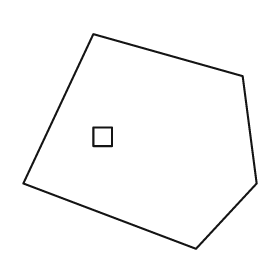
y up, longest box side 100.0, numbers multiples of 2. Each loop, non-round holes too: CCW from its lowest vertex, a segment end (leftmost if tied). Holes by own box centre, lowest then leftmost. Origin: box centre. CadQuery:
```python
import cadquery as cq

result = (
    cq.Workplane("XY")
    .moveTo(24.0, -46.0)
    .lineTo(50.0, -18.0)
    .lineTo(44.0, 28.0)
    .lineTo(-20.0, 46.0)
    .lineTo(-50.0, -18.0)
    .close()
    .moveTo(-20.0, -2.0)
    .lineTo(-12.0, -2.0)
    .lineTo(-12.0, 6.0)
    .lineTo(-20.0, 6.0)
    .close()
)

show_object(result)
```